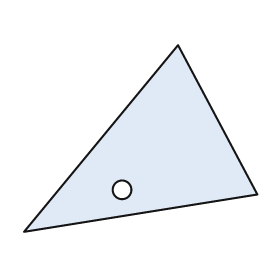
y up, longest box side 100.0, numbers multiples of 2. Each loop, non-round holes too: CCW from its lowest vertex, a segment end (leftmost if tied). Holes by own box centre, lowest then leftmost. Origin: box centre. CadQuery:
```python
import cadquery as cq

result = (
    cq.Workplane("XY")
    .moveTo(-50.0, -40.0)
    .lineTo(50.0, -24.0)
    .lineTo(16.0, 40.0)
    .close()
    .moveTo(-8.0, -22.0)
    .circle(4.0)
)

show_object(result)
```